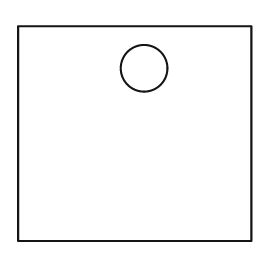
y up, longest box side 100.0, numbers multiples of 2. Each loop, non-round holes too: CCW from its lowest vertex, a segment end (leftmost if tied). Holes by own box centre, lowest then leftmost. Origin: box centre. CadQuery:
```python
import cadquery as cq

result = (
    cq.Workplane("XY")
    .moveTo(-50.0, -46.0)
    .lineTo(50.0, -46.0)
    .lineTo(50.0, 46.0)
    .lineTo(-50.0, 46.0)
    .close()
    .moveTo(4.0, 28.0)
    .circle(10.0)
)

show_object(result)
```